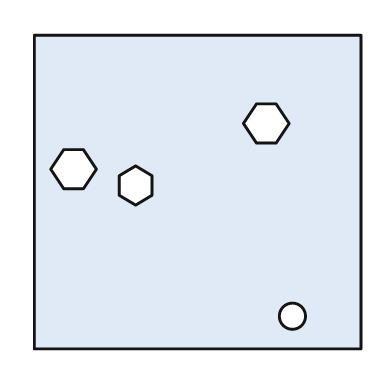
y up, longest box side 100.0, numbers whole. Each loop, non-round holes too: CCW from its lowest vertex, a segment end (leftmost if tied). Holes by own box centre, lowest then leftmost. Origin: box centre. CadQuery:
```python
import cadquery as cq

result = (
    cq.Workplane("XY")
    .moveTo(-50.0, -48.0)
    .lineTo(50.0, -48.0)
    .lineTo(50.0, 48.0)
    .lineTo(-50.0, 48.0)
    .close()
    .moveTo(29.0, -38.0)
    .circle(4.0)
    .moveTo(-19.0, -4.0)
    .lineTo(-14.0, -1.0)
    .lineTo(-14.0, 5.0)
    .lineTo(-19.0, 8.0)
    .lineTo(-24.0, 5.0)
    .lineTo(-24.0, -1.0)
    .close()
    .moveTo(-41.0, 1.0)
    .lineTo(-35.0, 1.0)
    .lineTo(-31.0, 7.0)
    .lineTo(-35.0, 13.0)
    .lineTo(-41.0, 13.0)
    .lineTo(-45.0, 7.0)
    .close()
    .moveTo(18.0, 15.0)
    .lineTo(24.0, 15.0)
    .lineTo(28.0, 21.0)
    .lineTo(24.0, 27.0)
    .lineTo(18.0, 27.0)
    .lineTo(14.0, 21.0)
    .close()
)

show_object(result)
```